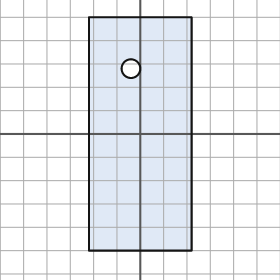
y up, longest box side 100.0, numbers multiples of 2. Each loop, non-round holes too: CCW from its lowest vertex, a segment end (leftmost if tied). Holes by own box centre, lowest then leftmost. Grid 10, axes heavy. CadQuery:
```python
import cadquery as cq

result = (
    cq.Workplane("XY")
    .moveTo(-22.0, -50.0)
    .lineTo(22.0, -50.0)
    .lineTo(22.0, 50.0)
    .lineTo(-22.0, 50.0)
    .close()
    .moveTo(-4.0, 28.0)
    .circle(4.0)
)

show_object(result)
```